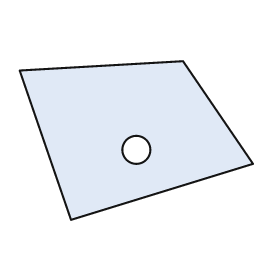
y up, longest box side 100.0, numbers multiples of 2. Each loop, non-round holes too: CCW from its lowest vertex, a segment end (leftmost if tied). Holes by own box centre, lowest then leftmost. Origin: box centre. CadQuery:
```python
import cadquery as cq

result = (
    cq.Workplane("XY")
    .moveTo(-28.0, -34.0)
    .lineTo(50.0, -10.0)
    .lineTo(20.0, 34.0)
    .lineTo(-50.0, 30.0)
    .close()
    .moveTo(0.0, -4.0)
    .circle(6.0)
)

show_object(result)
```